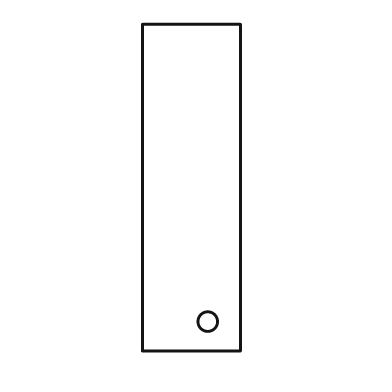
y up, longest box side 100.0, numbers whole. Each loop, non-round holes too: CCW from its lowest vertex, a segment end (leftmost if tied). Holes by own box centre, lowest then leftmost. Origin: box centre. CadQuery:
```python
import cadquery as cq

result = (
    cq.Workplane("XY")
    .moveTo(-15.0, -50.0)
    .lineTo(15.0, -50.0)
    .lineTo(15.0, 50.0)
    .lineTo(-15.0, 50.0)
    .close()
    .moveTo(5.0, -41.0)
    .circle(3.0)
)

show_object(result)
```